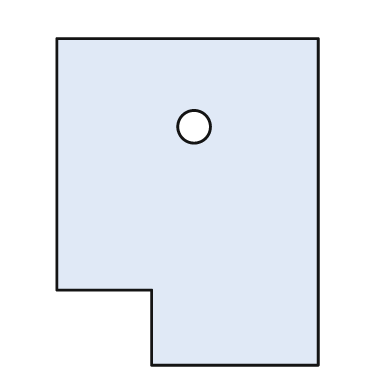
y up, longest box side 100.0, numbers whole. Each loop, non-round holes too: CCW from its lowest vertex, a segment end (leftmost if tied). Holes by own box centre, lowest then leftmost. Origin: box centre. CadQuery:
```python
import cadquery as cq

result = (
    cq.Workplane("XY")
    .moveTo(-11.0, -50.0)
    .lineTo(40.0, -50.0)
    .lineTo(40.0, 50.0)
    .lineTo(-40.0, 50.0)
    .lineTo(-40.0, -27.0)
    .lineTo(-11.0, -27.0)
    .close()
    .moveTo(2.0, 23.0)
    .circle(5.0)
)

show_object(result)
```